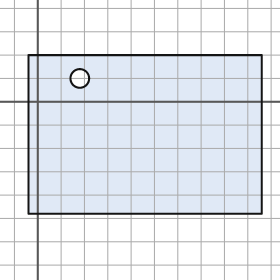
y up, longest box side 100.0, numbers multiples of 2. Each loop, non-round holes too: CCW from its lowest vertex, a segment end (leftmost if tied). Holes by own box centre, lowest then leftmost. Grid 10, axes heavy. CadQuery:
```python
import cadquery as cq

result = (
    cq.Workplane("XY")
    .moveTo(-4.0, -48.0)
    .lineTo(96.0, -48.0)
    .lineTo(96.0, 20.0)
    .lineTo(-4.0, 20.0)
    .close()
    .moveTo(18.0, 10.0)
    .circle(4.0)
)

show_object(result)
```